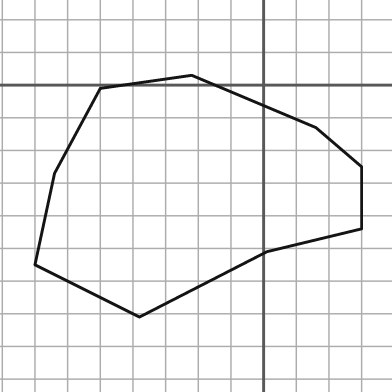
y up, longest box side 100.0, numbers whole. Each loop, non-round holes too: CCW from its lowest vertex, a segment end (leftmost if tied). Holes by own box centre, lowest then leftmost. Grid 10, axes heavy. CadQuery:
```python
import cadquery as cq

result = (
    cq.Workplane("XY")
    .moveTo(-38.0, -71.0)
    .lineTo(1.0, -51.0)
    .lineTo(30.0, -44.0)
    .lineTo(30.0, -25.0)
    .lineTo(16.0, -13.0)
    .lineTo(-22.0, 3.0)
    .lineTo(-50.0, -1.0)
    .lineTo(-64.0, -27.0)
    .lineTo(-70.0, -55.0)
    .close()
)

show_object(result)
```